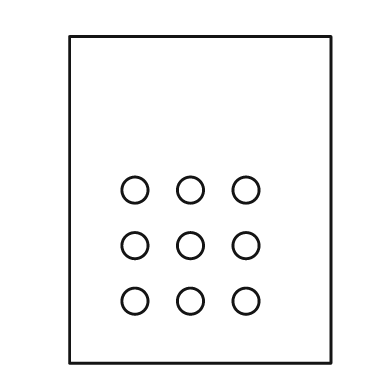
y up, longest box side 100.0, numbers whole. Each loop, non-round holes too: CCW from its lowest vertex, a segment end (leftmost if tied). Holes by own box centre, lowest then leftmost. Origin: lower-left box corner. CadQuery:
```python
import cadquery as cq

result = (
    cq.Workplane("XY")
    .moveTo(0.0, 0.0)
    .lineTo(80.0, 0.0)
    .lineTo(80.0, 100.0)
    .lineTo(0.0, 100.0)
    .close()
    .moveTo(20.0, 19.0)
    .circle(4.0)
    .moveTo(37.0, 19.0)
    .circle(4.0)
    .moveTo(54.0, 19.0)
    .circle(4.0)
    .moveTo(20.0, 36.0)
    .circle(4.0)
    .moveTo(37.0, 36.0)
    .circle(4.0)
    .moveTo(54.0, 36.0)
    .circle(4.0)
    .moveTo(20.0, 53.0)
    .circle(4.0)
    .moveTo(37.0, 53.0)
    .circle(4.0)
    .moveTo(54.0, 53.0)
    .circle(4.0)
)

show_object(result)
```